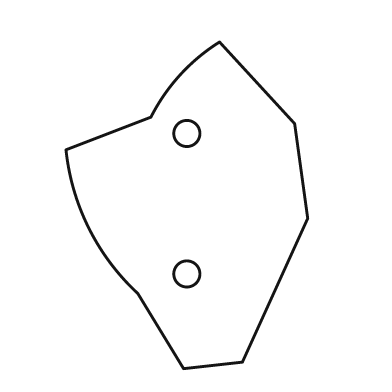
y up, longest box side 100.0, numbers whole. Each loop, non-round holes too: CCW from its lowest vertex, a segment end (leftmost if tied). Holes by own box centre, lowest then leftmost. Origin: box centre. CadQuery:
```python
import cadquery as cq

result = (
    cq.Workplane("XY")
    .moveTo(-1.0, -50.0)
    .lineTo(17.0, -48.0)
    .lineTo(37.0, -4.0)
    .lineTo(33.0, 25.0)
    .lineTo(10.0, 50.0)
    .threePointArc((-2.0, 40.0), (-11.0, 27.0))
    .lineTo(-37.0, 17.0)
    .threePointArc((-30.0, -7.0), (-15.0, -27.0))
    .close()
    .moveTo(0.0, -21.0)
    .circle(4.0)
    .moveTo(0.0, 22.0)
    .circle(4.0)
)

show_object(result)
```